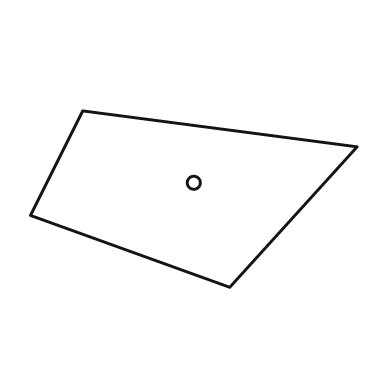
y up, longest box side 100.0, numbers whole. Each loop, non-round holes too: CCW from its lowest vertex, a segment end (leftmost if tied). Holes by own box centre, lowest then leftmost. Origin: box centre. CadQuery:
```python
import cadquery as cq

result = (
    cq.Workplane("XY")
    .moveTo(11.0, -27.0)
    .lineTo(50.0, 16.0)
    .lineTo(-34.0, 27.0)
    .lineTo(-50.0, -5.0)
    .close()
    .moveTo(0.0, 5.0)
    .circle(2.0)
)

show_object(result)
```